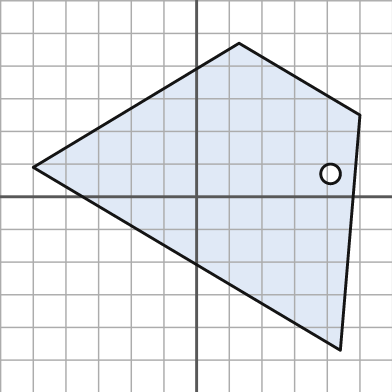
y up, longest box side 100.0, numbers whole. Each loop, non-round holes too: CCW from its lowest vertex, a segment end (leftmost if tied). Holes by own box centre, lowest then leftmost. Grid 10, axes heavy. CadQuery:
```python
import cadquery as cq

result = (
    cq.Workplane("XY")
    .moveTo(44.0, -47.0)
    .lineTo(50.0, 25.0)
    .lineTo(13.0, 47.0)
    .lineTo(-50.0, 9.0)
    .close()
    .moveTo(41.0, 7.0)
    .circle(3.0)
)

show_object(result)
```